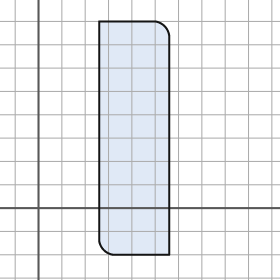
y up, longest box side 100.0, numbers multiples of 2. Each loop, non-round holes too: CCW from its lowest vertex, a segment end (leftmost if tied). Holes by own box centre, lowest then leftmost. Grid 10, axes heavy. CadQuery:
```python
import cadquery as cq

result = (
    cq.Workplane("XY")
    .moveTo(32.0, -20.0)
    .lineTo(56.0, -20.0)
    .lineTo(56.0, 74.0)
    .threePointArc((54.0, 78.0), (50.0, 80.0))
    .lineTo(26.0, 80.0)
    .lineTo(26.0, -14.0)
    .threePointArc((28.0, -18.0), (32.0, -20.0))
    .close()
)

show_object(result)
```